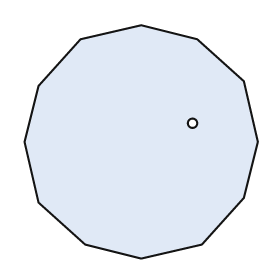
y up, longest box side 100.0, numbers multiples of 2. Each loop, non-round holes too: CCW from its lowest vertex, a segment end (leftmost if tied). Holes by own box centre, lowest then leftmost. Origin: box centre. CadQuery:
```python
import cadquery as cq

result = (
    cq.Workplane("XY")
    .moveTo(0.0, -50.0)
    .lineTo(26.0, -44.0)
    .lineTo(44.0, -24.0)
    .lineTo(50.0, 0.0)
    .lineTo(44.0, 26.0)
    .lineTo(24.0, 44.0)
    .lineTo(0.0, 50.0)
    .lineTo(-26.0, 44.0)
    .lineTo(-44.0, 24.0)
    .lineTo(-50.0, 0.0)
    .lineTo(-44.0, -26.0)
    .lineTo(-24.0, -44.0)
    .close()
    .moveTo(22.0, 8.0)
    .circle(2.0)
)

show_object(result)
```